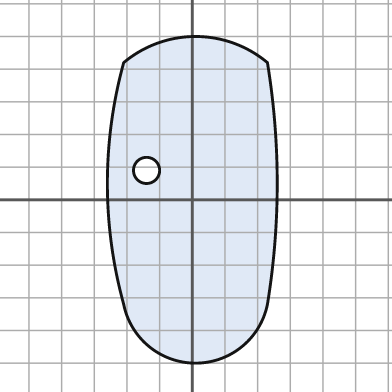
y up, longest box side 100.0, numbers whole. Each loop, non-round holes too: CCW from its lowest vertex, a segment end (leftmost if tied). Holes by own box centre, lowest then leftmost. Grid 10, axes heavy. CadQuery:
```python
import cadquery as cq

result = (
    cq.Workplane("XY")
    .moveTo(-21.0, -32.0)
    .threePointArc((1.0, -50.0), (23.0, -32.0))
    .threePointArc((26.0, 5.0), (23.0, 42.0))
    .threePointArc((1.0, 50.0), (-21.0, 42.0))
    .threePointArc((-26.0, 5.0), (-21.0, -32.0))
    .close()
    .moveTo(-14.0, 9.0)
    .circle(4.0)
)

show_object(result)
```